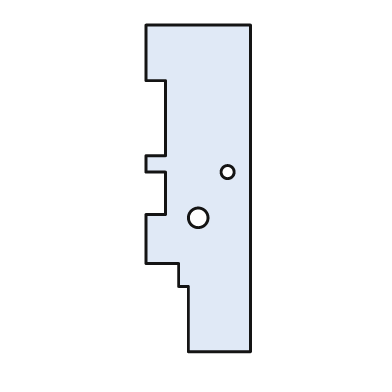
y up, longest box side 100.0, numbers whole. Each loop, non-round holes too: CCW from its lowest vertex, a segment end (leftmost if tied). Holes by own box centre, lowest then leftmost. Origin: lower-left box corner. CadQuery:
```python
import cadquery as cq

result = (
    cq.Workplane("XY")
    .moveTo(13.0, 0.0)
    .lineTo(32.0, 0.0)
    .lineTo(32.0, 100.0)
    .lineTo(0.0, 100.0)
    .lineTo(0.0, 83.0)
    .lineTo(6.0, 83.0)
    .lineTo(6.0, 60.0)
    .lineTo(0.0, 60.0)
    .lineTo(0.0, 55.0)
    .lineTo(6.0, 55.0)
    .lineTo(6.0, 42.0)
    .lineTo(0.0, 42.0)
    .lineTo(0.0, 27.0)
    .lineTo(10.0, 27.0)
    .lineTo(10.0, 20.0)
    .lineTo(13.0, 20.0)
    .close()
    .moveTo(16.0, 41.0)
    .circle(3.0)
    .moveTo(25.0, 55.0)
    .circle(2.0)
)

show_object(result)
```